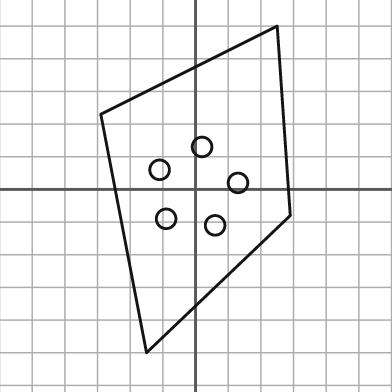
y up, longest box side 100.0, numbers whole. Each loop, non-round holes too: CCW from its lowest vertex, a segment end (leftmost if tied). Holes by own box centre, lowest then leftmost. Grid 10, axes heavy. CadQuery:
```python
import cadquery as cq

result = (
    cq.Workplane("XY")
    .moveTo(-15.0, -50.0)
    .lineTo(29.0, -8.0)
    .lineTo(25.0, 50.0)
    .lineTo(-29.0, 23.0)
    .close()
    .moveTo(6.0, -11.0)
    .circle(3.0)
    .moveTo(-9.0, -9.0)
    .circle(3.0)
    .moveTo(13.0, 2.0)
    .circle(3.0)
    .moveTo(-11.0, 6.0)
    .circle(3.0)
    .moveTo(2.0, 13.0)
    .circle(3.0)
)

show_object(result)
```